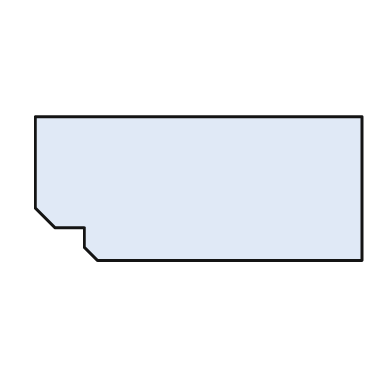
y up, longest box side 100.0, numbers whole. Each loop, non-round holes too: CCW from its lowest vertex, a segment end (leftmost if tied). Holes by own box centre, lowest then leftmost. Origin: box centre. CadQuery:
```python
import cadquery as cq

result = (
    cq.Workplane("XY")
    .moveTo(-31.0, -22.0)
    .lineTo(50.0, -22.0)
    .lineTo(50.0, 22.0)
    .lineTo(-50.0, 22.0)
    .lineTo(-50.0, -6.0)
    .lineTo(-44.0, -12.0)
    .lineTo(-35.0, -12.0)
    .lineTo(-35.0, -18.0)
    .close()
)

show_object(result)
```